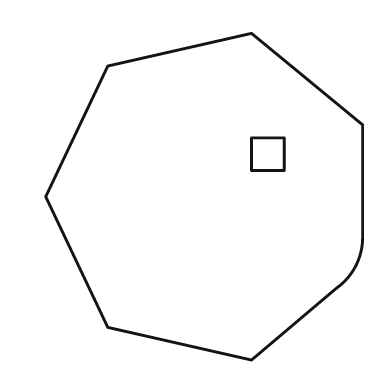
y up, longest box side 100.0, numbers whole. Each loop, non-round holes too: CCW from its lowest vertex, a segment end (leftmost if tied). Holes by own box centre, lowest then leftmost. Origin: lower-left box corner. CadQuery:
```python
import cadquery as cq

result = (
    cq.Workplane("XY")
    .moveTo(63.0, 0.0)
    .lineTo(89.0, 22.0)
    .threePointArc((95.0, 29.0), (97.0, 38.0))
    .lineTo(97.0, 72.0)
    .lineTo(63.0, 100.0)
    .lineTo(19.0, 90.0)
    .lineTo(0.0, 50.0)
    .lineTo(19.0, 10.0)
    .close()
    .moveTo(63.0, 58.0)
    .lineTo(73.0, 58.0)
    .lineTo(73.0, 68.0)
    .lineTo(63.0, 68.0)
    .close()
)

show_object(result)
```